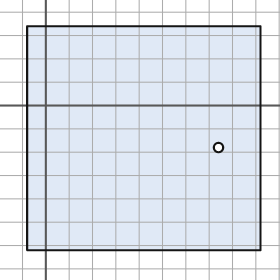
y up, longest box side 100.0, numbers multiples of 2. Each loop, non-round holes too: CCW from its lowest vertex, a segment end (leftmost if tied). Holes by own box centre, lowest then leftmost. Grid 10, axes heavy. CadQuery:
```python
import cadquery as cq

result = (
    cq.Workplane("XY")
    .moveTo(-8.0, -62.0)
    .lineTo(92.0, -62.0)
    .lineTo(92.0, 34.0)
    .lineTo(-8.0, 34.0)
    .close()
    .moveTo(74.0, -18.0)
    .circle(2.0)
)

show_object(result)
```